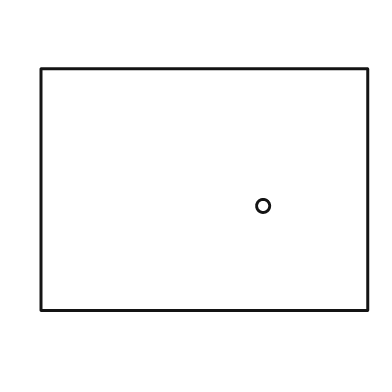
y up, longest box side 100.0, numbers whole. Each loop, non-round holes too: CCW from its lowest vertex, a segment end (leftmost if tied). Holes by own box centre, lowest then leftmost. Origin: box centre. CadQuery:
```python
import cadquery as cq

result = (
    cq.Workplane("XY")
    .moveTo(-50.0, -37.0)
    .lineTo(50.0, -37.0)
    .lineTo(50.0, 37.0)
    .lineTo(-50.0, 37.0)
    .close()
    .moveTo(18.0, -5.0)
    .circle(2.0)
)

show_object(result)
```